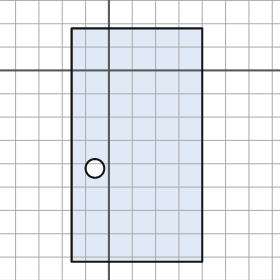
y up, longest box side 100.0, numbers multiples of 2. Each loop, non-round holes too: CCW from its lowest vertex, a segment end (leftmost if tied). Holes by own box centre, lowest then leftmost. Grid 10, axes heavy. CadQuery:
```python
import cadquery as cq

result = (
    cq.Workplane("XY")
    .moveTo(-16.0, -82.0)
    .lineTo(40.0, -82.0)
    .lineTo(40.0, 18.0)
    .lineTo(-16.0, 18.0)
    .close()
    .moveTo(-6.0, -42.0)
    .circle(4.0)
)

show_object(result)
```